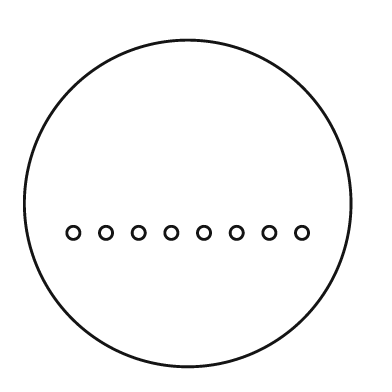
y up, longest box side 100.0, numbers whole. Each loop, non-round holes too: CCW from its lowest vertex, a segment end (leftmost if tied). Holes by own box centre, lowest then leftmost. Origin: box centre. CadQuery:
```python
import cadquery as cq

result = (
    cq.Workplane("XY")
    .moveTo(0.0, 0.0)
    .circle(50.0)
    .moveTo(-35.0, -9.0)
    .circle(2.0)
    .moveTo(-25.0, -9.0)
    .circle(2.0)
    .moveTo(-15.0, -9.0)
    .circle(2.0)
    .moveTo(-5.0, -9.0)
    .circle(2.0)
    .moveTo(5.0, -9.0)
    .circle(2.0)
    .moveTo(15.0, -9.0)
    .circle(2.0)
    .moveTo(25.0, -9.0)
    .circle(2.0)
    .moveTo(35.0, -9.0)
    .circle(2.0)
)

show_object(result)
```